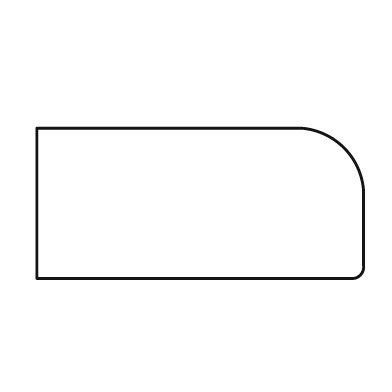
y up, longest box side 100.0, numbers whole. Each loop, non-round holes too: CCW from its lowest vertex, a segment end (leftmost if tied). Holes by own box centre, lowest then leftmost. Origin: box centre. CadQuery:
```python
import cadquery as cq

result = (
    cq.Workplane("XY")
    .moveTo(-50.0, -23.0)
    .lineTo(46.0, -23.0)
    .threePointArc((49.0, -22.0), (50.0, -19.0))
    .lineTo(50.0, 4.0)
    .threePointArc((44.0, 17.0), (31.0, 23.0))
    .lineTo(-50.0, 23.0)
    .close()
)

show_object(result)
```